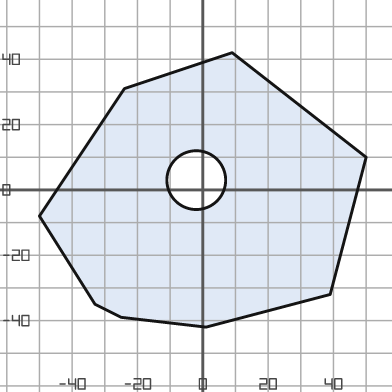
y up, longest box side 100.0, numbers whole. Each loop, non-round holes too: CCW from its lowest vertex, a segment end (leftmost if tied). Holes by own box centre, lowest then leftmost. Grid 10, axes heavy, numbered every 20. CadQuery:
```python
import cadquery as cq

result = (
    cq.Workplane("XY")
    .moveTo(1.0, -42.0)
    .lineTo(39.0, -32.0)
    .lineTo(50.0, 10.0)
    .lineTo(9.0, 42.0)
    .lineTo(-24.0, 31.0)
    .lineTo(-50.0, -8.0)
    .lineTo(-33.0, -35.0)
    .lineTo(-25.0, -39.0)
    .close()
    .moveTo(-2.0, 3.0)
    .circle(9.0)
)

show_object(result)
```